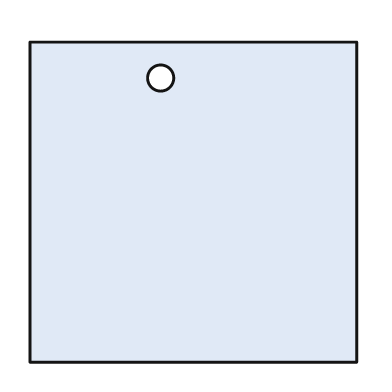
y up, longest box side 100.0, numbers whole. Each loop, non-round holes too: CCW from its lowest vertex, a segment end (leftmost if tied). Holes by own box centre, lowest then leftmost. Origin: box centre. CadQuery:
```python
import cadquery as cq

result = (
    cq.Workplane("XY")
    .moveTo(-50.0, -49.0)
    .lineTo(50.0, -49.0)
    .lineTo(50.0, 49.0)
    .lineTo(-50.0, 49.0)
    .close()
    .moveTo(-10.0, 38.0)
    .circle(4.0)
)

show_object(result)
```